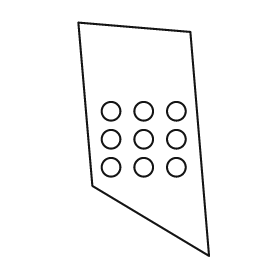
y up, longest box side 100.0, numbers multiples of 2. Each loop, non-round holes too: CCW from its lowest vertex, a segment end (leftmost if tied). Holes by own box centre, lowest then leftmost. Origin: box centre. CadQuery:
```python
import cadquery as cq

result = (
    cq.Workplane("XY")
    .moveTo(28.0, -50.0)
    .lineTo(20.0, 46.0)
    .lineTo(-28.0, 50.0)
    .lineTo(-22.0, -20.0)
    .close()
    .moveTo(-14.0, -12.0)
    .circle(4.0)
    .moveTo(0.0, -12.0)
    .circle(4.0)
    .moveTo(14.0, -12.0)
    .circle(4.0)
    .moveTo(-14.0, 0.0)
    .circle(4.0)
    .moveTo(0.0, 0.0)
    .circle(4.0)
    .moveTo(14.0, 0.0)
    .circle(4.0)
    .moveTo(-14.0, 12.0)
    .circle(4.0)
    .moveTo(0.0, 12.0)
    .circle(4.0)
    .moveTo(14.0, 12.0)
    .circle(4.0)
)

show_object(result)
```